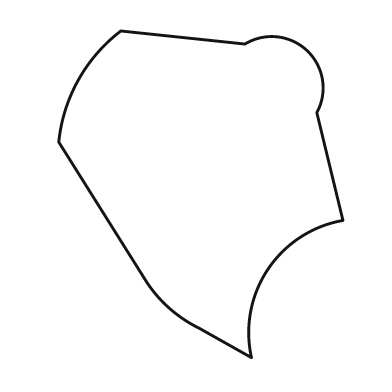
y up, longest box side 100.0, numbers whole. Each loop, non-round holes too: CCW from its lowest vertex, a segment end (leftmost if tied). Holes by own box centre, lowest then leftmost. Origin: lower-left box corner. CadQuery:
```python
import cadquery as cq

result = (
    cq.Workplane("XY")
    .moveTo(59.0, 0.0)
    .threePointArc((64.0, 27.0), (87.0, 42.0))
    .lineTo(79.0, 75.0)
    .threePointArc((76.0, 94.0), (57.0, 96.0))
    .lineTo(19.0, 100.0)
    .threePointArc((6.0, 85.0), (0.0, 66.0))
    .lineTo(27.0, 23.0)
    .threePointArc((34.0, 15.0), (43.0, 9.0))
    .close()
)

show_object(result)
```